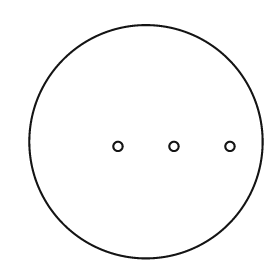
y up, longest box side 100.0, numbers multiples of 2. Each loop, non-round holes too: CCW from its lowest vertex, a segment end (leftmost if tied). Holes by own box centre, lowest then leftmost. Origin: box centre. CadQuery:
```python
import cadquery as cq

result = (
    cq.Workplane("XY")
    .moveTo(0.0, 0.0)
    .circle(50.0)
    .moveTo(-12.0, -2.0)
    .circle(2.0)
    .moveTo(12.0, -2.0)
    .circle(2.0)
    .moveTo(36.0, -2.0)
    .circle(2.0)
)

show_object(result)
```